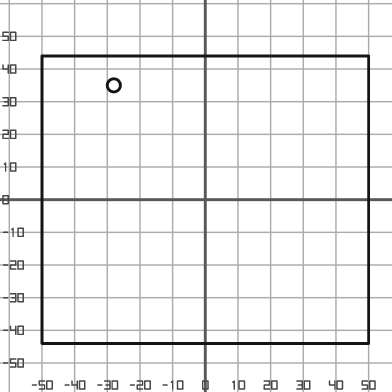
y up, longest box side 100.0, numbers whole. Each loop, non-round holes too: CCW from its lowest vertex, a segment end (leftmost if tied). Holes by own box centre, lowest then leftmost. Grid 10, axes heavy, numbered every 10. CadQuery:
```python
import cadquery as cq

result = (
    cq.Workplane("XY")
    .moveTo(-50.0, -44.0)
    .lineTo(50.0, -44.0)
    .lineTo(50.0, 44.0)
    .lineTo(-50.0, 44.0)
    .close()
    .moveTo(-28.0, 35.0)
    .circle(2.0)
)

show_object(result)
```